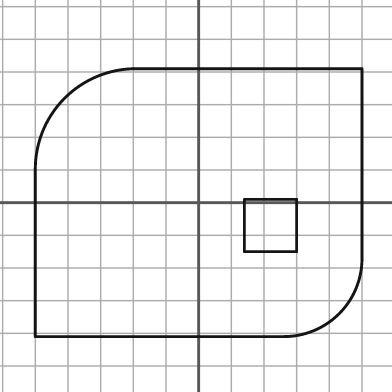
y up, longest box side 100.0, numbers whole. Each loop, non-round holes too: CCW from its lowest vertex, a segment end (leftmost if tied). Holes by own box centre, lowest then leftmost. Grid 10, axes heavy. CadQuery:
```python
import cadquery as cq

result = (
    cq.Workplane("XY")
    .moveTo(-50.0, -41.0)
    .lineTo(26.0, -41.0)
    .threePointArc((43.0, -34.0), (50.0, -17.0))
    .lineTo(50.0, 41.0)
    .lineTo(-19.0, 41.0)
    .threePointArc((-41.0, 32.0), (-50.0, 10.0))
    .close()
    .moveTo(14.0, -15.0)
    .lineTo(30.0, -15.0)
    .lineTo(30.0, 1.0)
    .lineTo(14.0, 1.0)
    .close()
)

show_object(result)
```